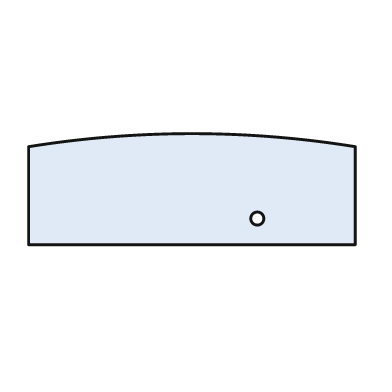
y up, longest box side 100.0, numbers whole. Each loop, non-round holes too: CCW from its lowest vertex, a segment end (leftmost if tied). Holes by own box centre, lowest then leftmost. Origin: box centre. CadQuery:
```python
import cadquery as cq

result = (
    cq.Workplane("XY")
    .moveTo(-50.0, -17.0)
    .lineTo(50.0, -17.0)
    .lineTo(50.0, 13.0)
    .threePointArc((0.0, 17.0), (-50.0, 13.0))
    .close()
    .moveTo(20.0, -9.0)
    .circle(2.0)
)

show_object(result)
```